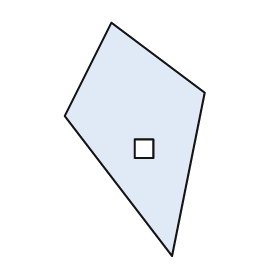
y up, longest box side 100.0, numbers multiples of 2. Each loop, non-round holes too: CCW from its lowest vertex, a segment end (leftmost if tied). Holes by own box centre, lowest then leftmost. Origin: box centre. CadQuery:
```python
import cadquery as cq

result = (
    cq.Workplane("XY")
    .moveTo(16.0, -50.0)
    .lineTo(30.0, 20.0)
    .lineTo(-10.0, 50.0)
    .lineTo(-30.0, 10.0)
    .close()
    .moveTo(0.0, -8.0)
    .lineTo(8.0, -8.0)
    .lineTo(8.0, 0.0)
    .lineTo(0.0, 0.0)
    .close()
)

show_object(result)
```